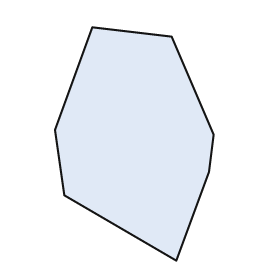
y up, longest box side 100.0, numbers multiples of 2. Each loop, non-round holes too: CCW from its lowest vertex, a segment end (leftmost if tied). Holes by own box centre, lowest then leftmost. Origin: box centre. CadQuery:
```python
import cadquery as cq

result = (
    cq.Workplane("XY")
    .moveTo(18.0, -50.0)
    .lineTo(32.0, -12.0)
    .lineTo(34.0, 4.0)
    .lineTo(16.0, 46.0)
    .lineTo(-18.0, 50.0)
    .lineTo(-34.0, 6.0)
    .lineTo(-30.0, -22.0)
    .close()
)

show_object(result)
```